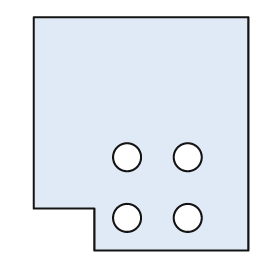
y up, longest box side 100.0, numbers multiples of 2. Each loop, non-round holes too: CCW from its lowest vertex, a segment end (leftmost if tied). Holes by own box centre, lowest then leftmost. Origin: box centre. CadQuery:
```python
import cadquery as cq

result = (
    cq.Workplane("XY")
    .moveTo(-20.0, -50.0)
    .lineTo(46.0, -50.0)
    .lineTo(46.0, 50.0)
    .lineTo(-46.0, 50.0)
    .lineTo(-46.0, -32.0)
    .lineTo(-20.0, -32.0)
    .close()
    .moveTo(-6.0, -36.0)
    .circle(6.0)
    .moveTo(20.0, -36.0)
    .circle(6.0)
    .moveTo(-6.0, -10.0)
    .circle(6.0)
    .moveTo(20.0, -10.0)
    .circle(6.0)
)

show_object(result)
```